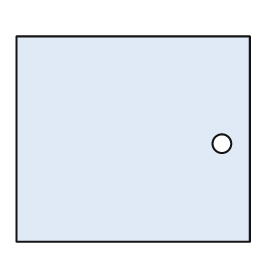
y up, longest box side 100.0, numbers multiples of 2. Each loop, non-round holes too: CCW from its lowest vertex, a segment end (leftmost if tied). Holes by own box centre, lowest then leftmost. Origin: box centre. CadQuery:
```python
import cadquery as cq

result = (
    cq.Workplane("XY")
    .moveTo(-50.0, -44.0)
    .lineTo(50.0, -44.0)
    .lineTo(50.0, 44.0)
    .lineTo(-50.0, 44.0)
    .close()
    .moveTo(38.0, -2.0)
    .circle(4.0)
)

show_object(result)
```